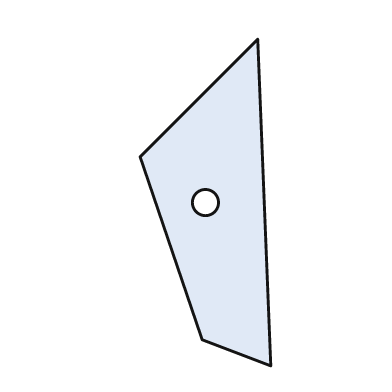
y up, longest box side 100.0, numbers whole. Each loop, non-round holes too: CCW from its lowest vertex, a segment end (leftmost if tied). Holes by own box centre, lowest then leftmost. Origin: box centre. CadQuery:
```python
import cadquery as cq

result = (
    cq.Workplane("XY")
    .moveTo(20.0, -50.0)
    .lineTo(16.0, 50.0)
    .lineTo(-20.0, 14.0)
    .lineTo(-1.0, -42.0)
    .close()
    .moveTo(0.0, 0.0)
    .circle(4.0)
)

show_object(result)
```